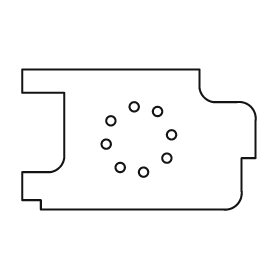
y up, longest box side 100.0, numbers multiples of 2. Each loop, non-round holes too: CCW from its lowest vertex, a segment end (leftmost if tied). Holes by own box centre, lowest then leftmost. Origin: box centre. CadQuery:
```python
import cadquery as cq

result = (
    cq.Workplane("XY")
    .moveTo(-42.0, -30.0)
    .lineTo(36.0, -30.0)
    .threePointArc((42.0, -28.0), (44.0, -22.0))
    .lineTo(44.0, -8.0)
    .lineTo(50.0, -8.0)
    .lineTo(50.0, 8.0)
    .threePointArc((48.0, 14.0), (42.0, 16.0))
    .lineTo(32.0, 16.0)
    .threePointArc((28.0, 18.0), (26.0, 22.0))
    .lineTo(26.0, 30.0)
    .lineTo(-50.0, 30.0)
    .lineTo(-50.0, 20.0)
    .lineTo(-32.0, 20.0)
    .lineTo(-32.0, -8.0)
    .threePointArc((-34.0, -12.0), (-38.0, -14.0))
    .lineTo(-50.0, -14.0)
    .lineTo(-50.0, -26.0)
    .lineTo(-42.0, -26.0)
    .close()
    .moveTo(2.0, -14.0)
    .circle(2.0)
    .moveTo(-8.0, -12.0)
    .circle(2.0)
    .moveTo(12.0, -8.0)
    .circle(2.0)
    .moveTo(-14.0, -2.0)
    .circle(2.0)
    .moveTo(14.0, 2.0)
    .circle(2.0)
    .moveTo(-12.0, 8.0)
    .circle(2.0)
    .moveTo(8.0, 12.0)
    .circle(2.0)
    .moveTo(-2.0, 14.0)
    .circle(2.0)
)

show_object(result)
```